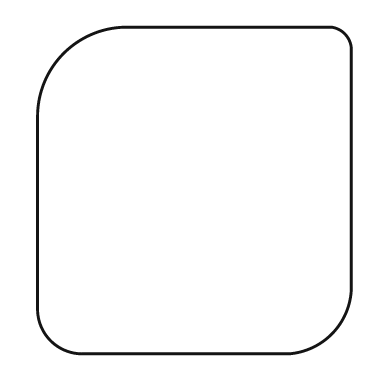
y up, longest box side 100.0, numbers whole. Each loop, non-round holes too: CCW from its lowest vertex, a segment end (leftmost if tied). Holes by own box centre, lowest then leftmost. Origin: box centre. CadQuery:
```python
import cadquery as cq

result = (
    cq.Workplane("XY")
    .moveTo(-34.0, -50.0)
    .lineTo(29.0, -50.0)
    .threePointArc((42.0, -44.0), (48.0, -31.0))
    .lineTo(48.0, 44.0)
    .threePointArc((46.0, 48.0), (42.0, 50.0))
    .lineTo(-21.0, 50.0)
    .threePointArc((-40.0, 42.0), (-48.0, 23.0))
    .lineTo(-48.0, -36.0)
    .threePointArc((-44.0, -46.0), (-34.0, -50.0))
    .close()
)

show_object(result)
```